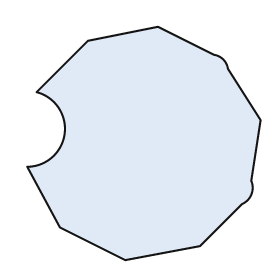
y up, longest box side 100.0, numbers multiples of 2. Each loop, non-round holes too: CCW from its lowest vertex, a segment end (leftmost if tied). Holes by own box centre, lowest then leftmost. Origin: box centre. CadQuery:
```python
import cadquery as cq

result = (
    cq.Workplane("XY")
    .moveTo(-8.0, -50.0)
    .lineTo(24.0, -44.0)
    .lineTo(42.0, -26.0)
    .threePointArc((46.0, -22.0), (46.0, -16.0))
    .lineTo(50.0, 10.0)
    .lineTo(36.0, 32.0)
    .threePointArc((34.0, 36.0), (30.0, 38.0))
    .lineTo(6.0, 50.0)
    .lineTo(-24.0, 44.0)
    .lineTo(-46.0, 22.0)
    .threePointArc((-34.0, 4.0), (-50.0, -10.0))
    .lineTo(-36.0, -36.0)
    .close()
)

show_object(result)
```